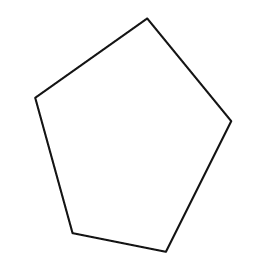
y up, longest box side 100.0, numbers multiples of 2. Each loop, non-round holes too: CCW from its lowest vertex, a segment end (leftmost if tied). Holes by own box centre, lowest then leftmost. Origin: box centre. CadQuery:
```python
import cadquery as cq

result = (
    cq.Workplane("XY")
    .moveTo(14.0, -50.0)
    .lineTo(42.0, 6.0)
    .lineTo(6.0, 50.0)
    .lineTo(-42.0, 16.0)
    .lineTo(-26.0, -42.0)
    .close()
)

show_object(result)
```